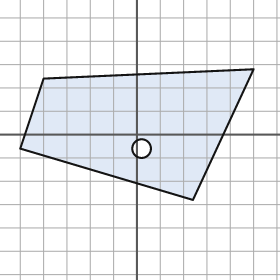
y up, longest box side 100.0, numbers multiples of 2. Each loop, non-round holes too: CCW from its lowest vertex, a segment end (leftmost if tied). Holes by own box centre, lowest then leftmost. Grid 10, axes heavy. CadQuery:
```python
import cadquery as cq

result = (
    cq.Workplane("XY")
    .moveTo(24.0, -28.0)
    .lineTo(50.0, 28.0)
    .lineTo(-40.0, 24.0)
    .lineTo(-50.0, -6.0)
    .close()
    .moveTo(2.0, -6.0)
    .circle(4.0)
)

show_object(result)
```